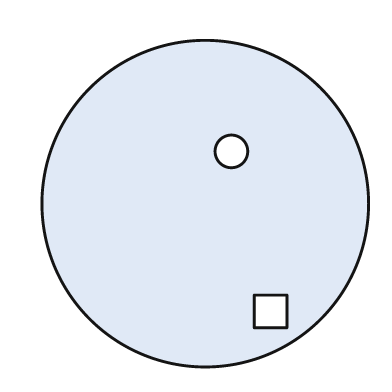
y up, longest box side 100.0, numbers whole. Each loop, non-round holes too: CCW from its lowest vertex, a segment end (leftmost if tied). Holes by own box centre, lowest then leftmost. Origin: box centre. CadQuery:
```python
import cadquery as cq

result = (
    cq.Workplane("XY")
    .moveTo(0.0, 0.0)
    .circle(50.0)
    .moveTo(15.0, -38.0)
    .lineTo(25.0, -38.0)
    .lineTo(25.0, -28.0)
    .lineTo(15.0, -28.0)
    .close()
    .moveTo(8.0, 16.0)
    .circle(5.0)
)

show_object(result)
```